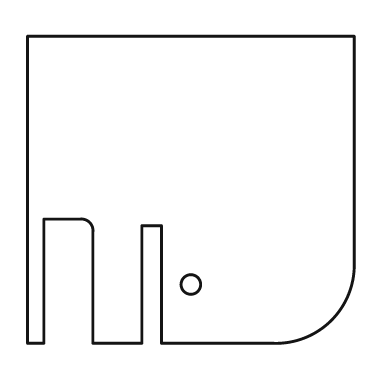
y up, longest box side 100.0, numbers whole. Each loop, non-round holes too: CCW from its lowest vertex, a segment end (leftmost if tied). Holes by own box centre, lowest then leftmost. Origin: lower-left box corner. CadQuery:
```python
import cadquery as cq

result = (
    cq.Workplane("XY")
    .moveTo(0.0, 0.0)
    .lineTo(5.0, 0.0)
    .lineTo(5.0, 38.0)
    .lineTo(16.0, 38.0)
    .threePointArc((19.0, 37.0), (20.0, 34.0))
    .lineTo(20.0, 0.0)
    .lineTo(35.0, 0.0)
    .lineTo(35.0, 36.0)
    .lineTo(41.0, 36.0)
    .lineTo(41.0, 0.0)
    .lineTo(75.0, 0.0)
    .threePointArc((93.0, 7.0), (100.0, 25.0))
    .lineTo(100.0, 94.0)
    .lineTo(0.0, 94.0)
    .close()
    .moveTo(50.0, 18.0)
    .circle(3.0)
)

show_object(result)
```